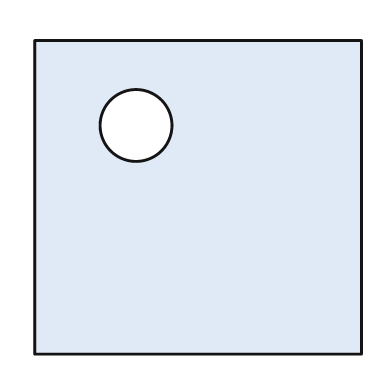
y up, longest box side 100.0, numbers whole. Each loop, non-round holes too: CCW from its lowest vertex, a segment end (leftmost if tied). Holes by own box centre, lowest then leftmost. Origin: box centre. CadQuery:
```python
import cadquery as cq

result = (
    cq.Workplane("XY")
    .moveTo(-50.0, -48.0)
    .lineTo(50.0, -48.0)
    .lineTo(50.0, 48.0)
    .lineTo(-50.0, 48.0)
    .close()
    .moveTo(-19.0, 22.0)
    .circle(11.0)
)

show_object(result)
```